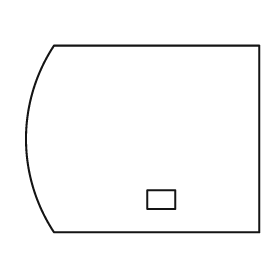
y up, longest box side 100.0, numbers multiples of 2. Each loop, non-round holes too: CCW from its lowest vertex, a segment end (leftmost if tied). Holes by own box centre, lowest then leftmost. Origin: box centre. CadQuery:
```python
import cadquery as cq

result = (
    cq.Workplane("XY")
    .moveTo(-38.0, -40.0)
    .lineTo(50.0, -40.0)
    .lineTo(50.0, 40.0)
    .lineTo(-38.0, 40.0)
    .threePointArc((-50.0, 0.0), (-38.0, -40.0))
    .close()
    .moveTo(2.0, -30.0)
    .lineTo(14.0, -30.0)
    .lineTo(14.0, -22.0)
    .lineTo(2.0, -22.0)
    .close()
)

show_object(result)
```